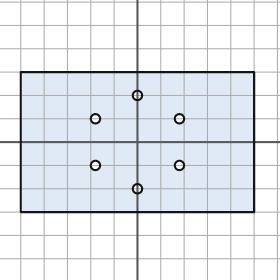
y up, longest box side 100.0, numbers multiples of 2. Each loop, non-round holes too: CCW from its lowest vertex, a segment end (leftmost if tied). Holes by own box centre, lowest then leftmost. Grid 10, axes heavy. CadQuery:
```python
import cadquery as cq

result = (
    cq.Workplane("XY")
    .moveTo(-50.0, -30.0)
    .lineTo(50.0, -30.0)
    .lineTo(50.0, 30.0)
    .lineTo(-50.0, 30.0)
    .close()
    .moveTo(0.0, -20.0)
    .circle(2.0)
    .moveTo(-18.0, -10.0)
    .circle(2.0)
    .moveTo(18.0, -10.0)
    .circle(2.0)
    .moveTo(-18.0, 10.0)
    .circle(2.0)
    .moveTo(18.0, 10.0)
    .circle(2.0)
    .moveTo(0.0, 20.0)
    .circle(2.0)
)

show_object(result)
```